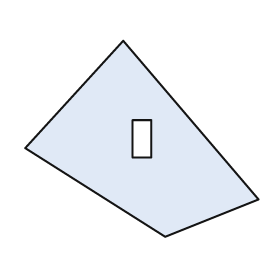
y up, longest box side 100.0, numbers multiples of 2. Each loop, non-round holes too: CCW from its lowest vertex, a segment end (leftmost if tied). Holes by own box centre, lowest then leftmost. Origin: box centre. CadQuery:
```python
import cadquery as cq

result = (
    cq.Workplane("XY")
    .moveTo(10.0, -42.0)
    .lineTo(50.0, -26.0)
    .lineTo(-8.0, 42.0)
    .lineTo(-50.0, -4.0)
    .close()
    .moveTo(-4.0, -8.0)
    .lineTo(4.0, -8.0)
    .lineTo(4.0, 8.0)
    .lineTo(-4.0, 8.0)
    .close()
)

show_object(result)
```